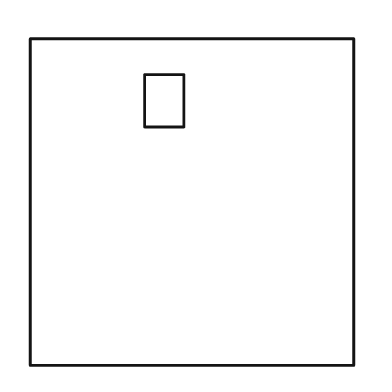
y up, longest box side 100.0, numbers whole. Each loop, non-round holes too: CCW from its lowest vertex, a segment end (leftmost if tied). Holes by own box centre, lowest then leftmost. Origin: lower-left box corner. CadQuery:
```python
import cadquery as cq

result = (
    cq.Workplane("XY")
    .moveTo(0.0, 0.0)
    .lineTo(99.0, 0.0)
    .lineTo(99.0, 100.0)
    .lineTo(0.0, 100.0)
    .close()
    .moveTo(35.0, 73.0)
    .lineTo(47.0, 73.0)
    .lineTo(47.0, 89.0)
    .lineTo(35.0, 89.0)
    .close()
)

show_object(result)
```